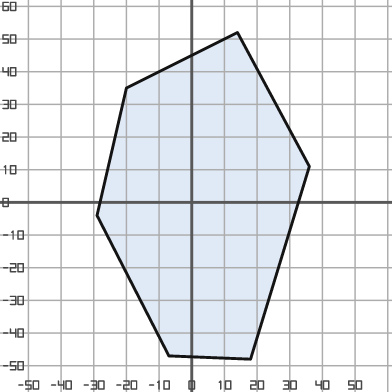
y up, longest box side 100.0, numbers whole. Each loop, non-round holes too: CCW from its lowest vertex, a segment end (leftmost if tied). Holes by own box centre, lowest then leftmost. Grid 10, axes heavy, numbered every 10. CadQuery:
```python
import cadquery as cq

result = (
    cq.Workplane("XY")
    .moveTo(18.0, -48.0)
    .lineTo(36.0, 11.0)
    .lineTo(14.0, 52.0)
    .lineTo(-20.0, 35.0)
    .lineTo(-29.0, -4.0)
    .lineTo(-7.0, -47.0)
    .close()
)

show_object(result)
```